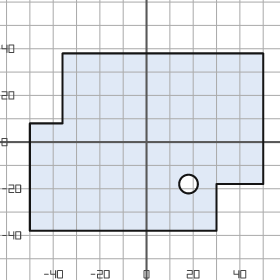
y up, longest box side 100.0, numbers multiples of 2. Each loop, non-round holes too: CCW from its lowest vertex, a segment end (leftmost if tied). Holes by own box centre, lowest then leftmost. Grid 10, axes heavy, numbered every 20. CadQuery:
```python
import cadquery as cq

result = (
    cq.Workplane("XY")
    .moveTo(-50.0, -38.0)
    .lineTo(30.0, -38.0)
    .lineTo(30.0, -18.0)
    .lineTo(50.0, -18.0)
    .lineTo(50.0, 38.0)
    .lineTo(-36.0, 38.0)
    .lineTo(-36.0, 8.0)
    .lineTo(-50.0, 8.0)
    .close()
    .moveTo(18.0, -18.0)
    .circle(4.0)
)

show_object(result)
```